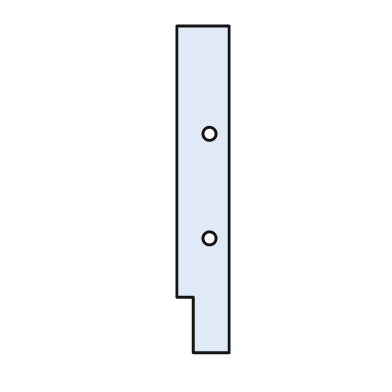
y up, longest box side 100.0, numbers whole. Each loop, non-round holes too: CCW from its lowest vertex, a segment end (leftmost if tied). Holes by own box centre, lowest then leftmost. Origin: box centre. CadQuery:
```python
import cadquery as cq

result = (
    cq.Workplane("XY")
    .moveTo(-3.0, -50.0)
    .lineTo(8.0, -50.0)
    .lineTo(8.0, 50.0)
    .lineTo(-8.0, 50.0)
    .lineTo(-8.0, -33.0)
    .lineTo(-3.0, -33.0)
    .close()
    .moveTo(2.0, -15.0)
    .circle(2.0)
    .moveTo(2.0, 17.0)
    .circle(2.0)
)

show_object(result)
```